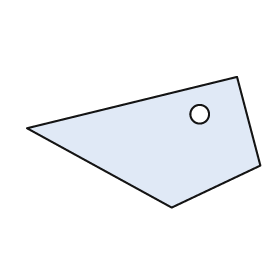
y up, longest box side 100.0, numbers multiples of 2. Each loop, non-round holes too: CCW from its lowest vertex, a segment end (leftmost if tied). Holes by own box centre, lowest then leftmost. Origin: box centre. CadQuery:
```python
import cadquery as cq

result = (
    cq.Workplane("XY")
    .moveTo(12.0, -28.0)
    .lineTo(50.0, -10.0)
    .lineTo(40.0, 28.0)
    .lineTo(-50.0, 6.0)
    .close()
    .moveTo(24.0, 12.0)
    .circle(4.0)
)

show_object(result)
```